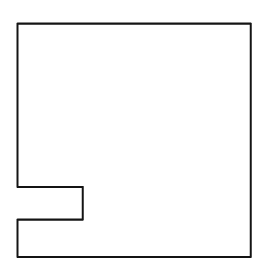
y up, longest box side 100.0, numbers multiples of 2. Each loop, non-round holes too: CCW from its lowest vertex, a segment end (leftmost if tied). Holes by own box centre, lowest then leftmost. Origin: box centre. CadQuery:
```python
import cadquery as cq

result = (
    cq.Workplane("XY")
    .moveTo(-50.0, -50.0)
    .lineTo(50.0, -50.0)
    .lineTo(50.0, 50.0)
    .lineTo(-50.0, 50.0)
    .lineTo(-50.0, -20.0)
    .lineTo(-22.0, -20.0)
    .lineTo(-22.0, -34.0)
    .lineTo(-50.0, -34.0)
    .close()
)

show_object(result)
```